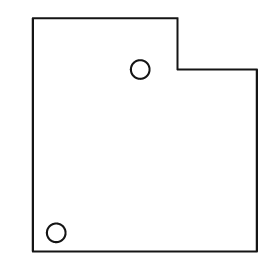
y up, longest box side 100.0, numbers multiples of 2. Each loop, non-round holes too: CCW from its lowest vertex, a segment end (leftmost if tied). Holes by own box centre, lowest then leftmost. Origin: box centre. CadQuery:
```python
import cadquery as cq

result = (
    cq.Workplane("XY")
    .moveTo(-48.0, -50.0)
    .lineTo(48.0, -50.0)
    .lineTo(48.0, 28.0)
    .lineTo(14.0, 28.0)
    .lineTo(14.0, 50.0)
    .lineTo(-48.0, 50.0)
    .close()
    .moveTo(-38.0, -42.0)
    .circle(4.0)
    .moveTo(-2.0, 28.0)
    .circle(4.0)
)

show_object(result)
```